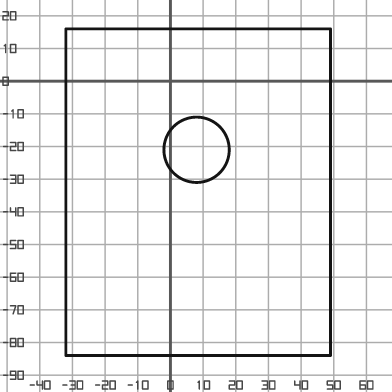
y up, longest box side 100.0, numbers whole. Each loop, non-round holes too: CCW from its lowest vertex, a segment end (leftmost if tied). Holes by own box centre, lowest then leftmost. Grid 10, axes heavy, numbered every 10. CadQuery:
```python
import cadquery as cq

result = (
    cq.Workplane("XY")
    .moveTo(-32.0, -84.0)
    .lineTo(49.0, -84.0)
    .lineTo(49.0, 16.0)
    .lineTo(-32.0, 16.0)
    .close()
    .moveTo(8.0, -21.0)
    .circle(10.0)
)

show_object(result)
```